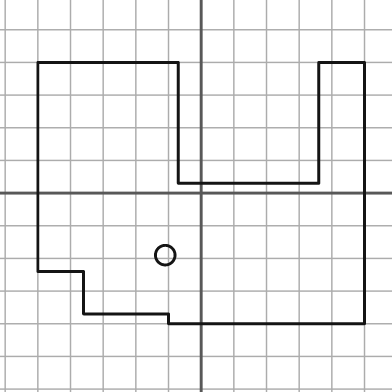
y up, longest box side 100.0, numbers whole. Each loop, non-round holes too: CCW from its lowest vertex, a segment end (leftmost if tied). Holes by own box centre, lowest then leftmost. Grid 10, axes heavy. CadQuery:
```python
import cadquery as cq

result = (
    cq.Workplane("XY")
    .moveTo(-10.0, -40.0)
    .lineTo(50.0, -40.0)
    .lineTo(50.0, 40.0)
    .lineTo(36.0, 40.0)
    .lineTo(36.0, 3.0)
    .lineTo(-7.0, 3.0)
    .lineTo(-7.0, 40.0)
    .lineTo(-50.0, 40.0)
    .lineTo(-50.0, -24.0)
    .lineTo(-36.0, -24.0)
    .lineTo(-36.0, -37.0)
    .lineTo(-10.0, -37.0)
    .close()
    .moveTo(-11.0, -19.0)
    .circle(3.0)
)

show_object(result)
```